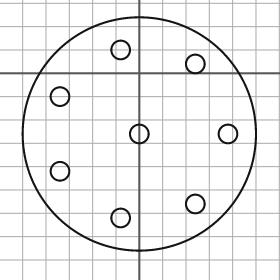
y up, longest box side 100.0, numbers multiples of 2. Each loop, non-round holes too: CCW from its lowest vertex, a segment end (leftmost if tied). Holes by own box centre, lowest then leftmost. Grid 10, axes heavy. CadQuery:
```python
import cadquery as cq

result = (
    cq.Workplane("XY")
    .moveTo(0.0, -26.0)
    .circle(50.0)
    .moveTo(-8.0, -62.0)
    .circle(4.0)
    .moveTo(24.0, -56.0)
    .circle(4.0)
    .moveTo(-34.0, -42.0)
    .circle(4.0)
    .moveTo(0.0, -26.0)
    .circle(4.0)
    .moveTo(38.0, -26.0)
    .circle(4.0)
    .moveTo(-34.0, -10.0)
    .circle(4.0)
    .moveTo(24.0, 4.0)
    .circle(4.0)
    .moveTo(-8.0, 10.0)
    .circle(4.0)
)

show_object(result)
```